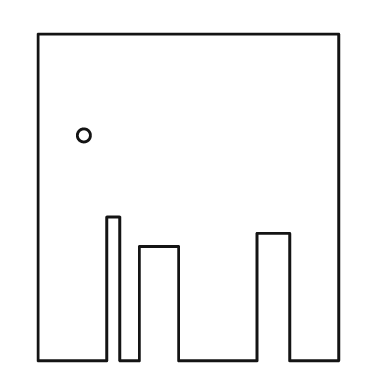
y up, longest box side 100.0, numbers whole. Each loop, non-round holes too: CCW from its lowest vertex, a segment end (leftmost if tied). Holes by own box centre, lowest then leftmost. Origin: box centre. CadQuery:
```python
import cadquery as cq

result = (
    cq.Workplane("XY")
    .moveTo(-46.0, -50.0)
    .lineTo(-25.0, -50.0)
    .lineTo(-25.0, -6.0)
    .lineTo(-21.0, -6.0)
    .lineTo(-21.0, -50.0)
    .lineTo(-15.0, -50.0)
    .lineTo(-15.0, -15.0)
    .lineTo(-3.0, -15.0)
    .lineTo(-3.0, -50.0)
    .lineTo(21.0, -50.0)
    .lineTo(21.0, -11.0)
    .lineTo(31.0, -11.0)
    .lineTo(31.0, -50.0)
    .lineTo(46.0, -50.0)
    .lineTo(46.0, 50.0)
    .lineTo(-46.0, 50.0)
    .close()
    .moveTo(-32.0, 19.0)
    .circle(2.0)
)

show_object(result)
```